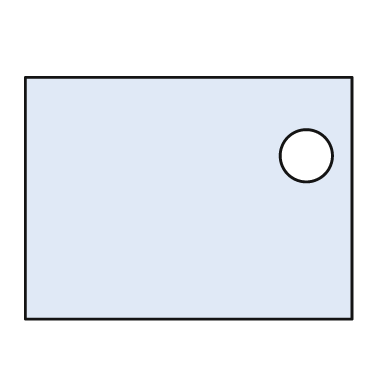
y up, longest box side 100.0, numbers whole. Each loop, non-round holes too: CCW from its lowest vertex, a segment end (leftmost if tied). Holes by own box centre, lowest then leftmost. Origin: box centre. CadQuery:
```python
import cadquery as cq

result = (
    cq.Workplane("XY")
    .moveTo(-50.0, -37.0)
    .lineTo(50.0, -37.0)
    .lineTo(50.0, 37.0)
    .lineTo(-50.0, 37.0)
    .close()
    .moveTo(36.0, 13.0)
    .circle(8.0)
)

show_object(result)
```